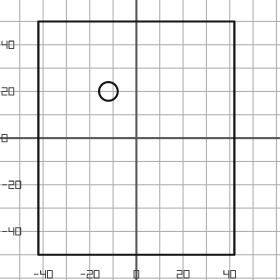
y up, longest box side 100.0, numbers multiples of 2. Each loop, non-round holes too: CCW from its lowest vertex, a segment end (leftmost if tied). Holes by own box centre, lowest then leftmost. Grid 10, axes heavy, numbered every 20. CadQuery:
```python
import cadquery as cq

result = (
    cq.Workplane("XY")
    .moveTo(-42.0, -50.0)
    .lineTo(42.0, -50.0)
    .lineTo(42.0, 50.0)
    .lineTo(-42.0, 50.0)
    .close()
    .moveTo(-12.0, 20.0)
    .circle(4.0)
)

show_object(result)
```